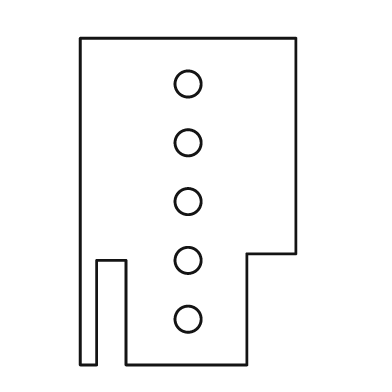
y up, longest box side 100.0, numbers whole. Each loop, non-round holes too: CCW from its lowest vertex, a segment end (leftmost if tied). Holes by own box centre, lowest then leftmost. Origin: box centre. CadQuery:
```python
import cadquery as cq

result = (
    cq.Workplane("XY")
    .moveTo(-33.0, -50.0)
    .lineTo(-28.0, -50.0)
    .lineTo(-28.0, -18.0)
    .lineTo(-19.0, -18.0)
    .lineTo(-19.0, -50.0)
    .lineTo(18.0, -50.0)
    .lineTo(18.0, -16.0)
    .lineTo(33.0, -16.0)
    .lineTo(33.0, 50.0)
    .lineTo(-33.0, 50.0)
    .close()
    .moveTo(0.0, -36.0)
    .circle(4.0)
    .moveTo(0.0, -18.0)
    .circle(4.0)
    .moveTo(0.0, 0.0)
    .circle(4.0)
    .moveTo(0.0, 18.0)
    .circle(4.0)
    .moveTo(0.0, 36.0)
    .circle(4.0)
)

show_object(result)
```